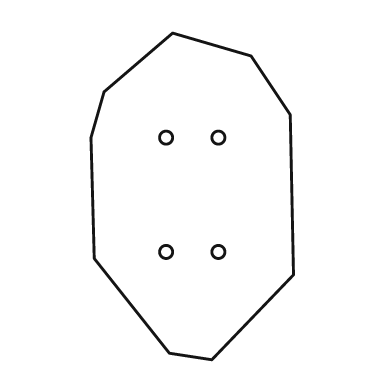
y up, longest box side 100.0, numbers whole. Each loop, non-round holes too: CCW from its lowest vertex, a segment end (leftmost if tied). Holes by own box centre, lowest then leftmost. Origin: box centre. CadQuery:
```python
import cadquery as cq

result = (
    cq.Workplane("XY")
    .moveTo(6.0, -50.0)
    .lineTo(31.0, -24.0)
    .lineTo(30.0, 25.0)
    .lineTo(18.0, 43.0)
    .lineTo(-6.0, 50.0)
    .lineTo(-27.0, 32.0)
    .lineTo(-31.0, 18.0)
    .lineTo(-30.0, -19.0)
    .lineTo(-7.0, -48.0)
    .close()
    .moveTo(-8.0, -17.0)
    .circle(2.0)
    .moveTo(8.0, -17.0)
    .circle(2.0)
    .moveTo(-8.0, 18.0)
    .circle(2.0)
    .moveTo(8.0, 18.0)
    .circle(2.0)
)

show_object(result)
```